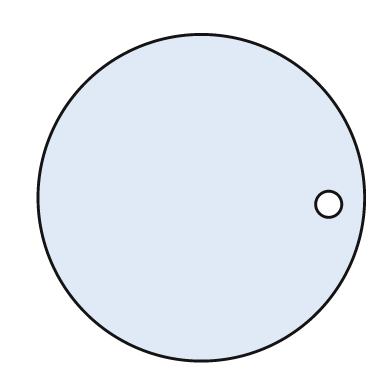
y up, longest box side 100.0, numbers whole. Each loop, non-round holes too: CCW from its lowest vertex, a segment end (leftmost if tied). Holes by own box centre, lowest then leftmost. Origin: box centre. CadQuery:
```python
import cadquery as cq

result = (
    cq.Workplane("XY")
    .moveTo(0.0, 0.0)
    .circle(50.0)
    .moveTo(39.0, -2.0)
    .circle(4.0)
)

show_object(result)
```